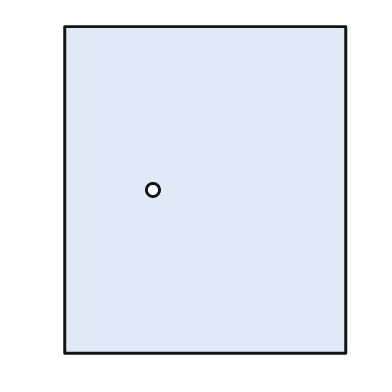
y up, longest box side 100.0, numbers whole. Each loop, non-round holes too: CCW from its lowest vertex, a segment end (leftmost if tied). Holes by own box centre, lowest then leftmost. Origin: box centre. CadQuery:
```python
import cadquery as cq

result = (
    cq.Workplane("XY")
    .moveTo(-43.0, -50.0)
    .lineTo(43.0, -50.0)
    .lineTo(43.0, 50.0)
    .lineTo(-43.0, 50.0)
    .close()
    .moveTo(-16.0, 0.0)
    .circle(2.0)
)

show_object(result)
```